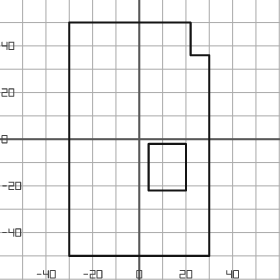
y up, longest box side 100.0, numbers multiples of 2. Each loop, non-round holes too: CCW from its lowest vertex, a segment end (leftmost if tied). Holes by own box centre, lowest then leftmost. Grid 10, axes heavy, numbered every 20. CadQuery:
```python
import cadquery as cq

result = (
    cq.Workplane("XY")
    .moveTo(-30.0, -50.0)
    .lineTo(30.0, -50.0)
    .lineTo(30.0, 36.0)
    .lineTo(22.0, 36.0)
    .lineTo(22.0, 50.0)
    .lineTo(-30.0, 50.0)
    .close()
    .moveTo(4.0, -22.0)
    .lineTo(20.0, -22.0)
    .lineTo(20.0, -2.0)
    .lineTo(4.0, -2.0)
    .close()
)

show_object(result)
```